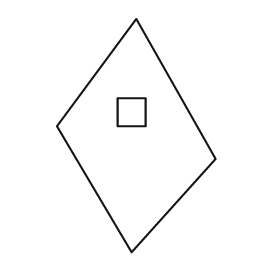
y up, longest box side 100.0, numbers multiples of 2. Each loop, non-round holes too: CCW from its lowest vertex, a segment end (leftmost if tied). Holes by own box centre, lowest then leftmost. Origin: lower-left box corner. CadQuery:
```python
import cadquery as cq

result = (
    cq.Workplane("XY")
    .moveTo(32.0, 0.0)
    .lineTo(68.0, 40.0)
    .lineTo(34.0, 100.0)
    .lineTo(0.0, 54.0)
    .close()
    .moveTo(26.0, 54.0)
    .lineTo(38.0, 54.0)
    .lineTo(38.0, 66.0)
    .lineTo(26.0, 66.0)
    .close()
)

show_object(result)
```